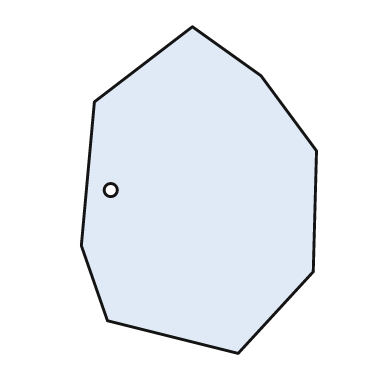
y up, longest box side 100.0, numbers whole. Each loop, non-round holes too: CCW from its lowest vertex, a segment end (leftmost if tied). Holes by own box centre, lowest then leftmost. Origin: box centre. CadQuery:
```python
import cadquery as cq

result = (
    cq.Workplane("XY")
    .moveTo(12.0, -50.0)
    .lineTo(35.0, -25.0)
    .lineTo(36.0, 12.0)
    .lineTo(19.0, 35.0)
    .lineTo(-2.0, 50.0)
    .lineTo(-32.0, 27.0)
    .lineTo(-36.0, -17.0)
    .lineTo(-28.0, -40.0)
    .close()
    .moveTo(-27.0, 0.0)
    .circle(2.0)
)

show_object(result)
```